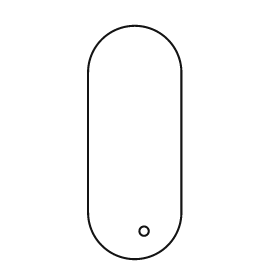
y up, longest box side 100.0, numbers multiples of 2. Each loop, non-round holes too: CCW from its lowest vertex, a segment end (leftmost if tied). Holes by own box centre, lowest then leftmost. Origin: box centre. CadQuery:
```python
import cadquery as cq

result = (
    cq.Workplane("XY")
    .moveTo(-20.0, -30.0)
    .threePointArc((0.0, -50.0), (20.0, -30.0))
    .lineTo(20.0, 30.0)
    .threePointArc((0.0, 50.0), (-20.0, 30.0))
    .close()
    .moveTo(4.0, -38.0)
    .circle(2.0)
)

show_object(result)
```